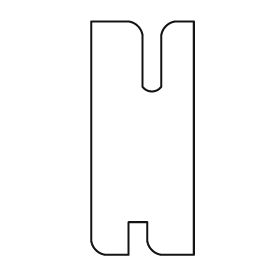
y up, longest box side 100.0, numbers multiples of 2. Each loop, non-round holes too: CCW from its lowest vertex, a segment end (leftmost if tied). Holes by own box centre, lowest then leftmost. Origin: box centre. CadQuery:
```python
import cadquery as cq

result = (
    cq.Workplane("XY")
    .moveTo(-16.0, -50.0)
    .lineTo(-6.0, -50.0)
    .lineTo(-6.0, -36.0)
    .lineTo(2.0, -36.0)
    .lineTo(2.0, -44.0)
    .threePointArc((4.0, -48.0), (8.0, -50.0))
    .lineTo(22.0, -50.0)
    .lineTo(22.0, 50.0)
    .lineTo(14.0, 50.0)
    .threePointArc((10.0, 48.0), (8.0, 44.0))
    .lineTo(8.0, 22.0)
    .threePointArc((4.0, 20.0), (0.0, 22.0))
    .lineTo(0.0, 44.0)
    .threePointArc((-2.0, 48.0), (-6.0, 50.0))
    .lineTo(-22.0, 50.0)
    .lineTo(-22.0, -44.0)
    .threePointArc((-20.0, -48.0), (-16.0, -50.0))
    .close()
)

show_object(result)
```